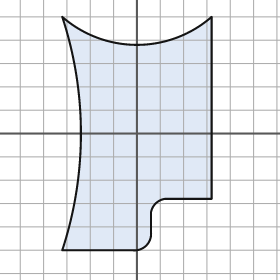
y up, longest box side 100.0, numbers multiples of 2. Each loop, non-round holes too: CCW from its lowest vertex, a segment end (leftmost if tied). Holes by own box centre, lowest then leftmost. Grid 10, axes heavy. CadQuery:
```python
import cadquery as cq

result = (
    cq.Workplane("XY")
    .moveTo(-32.0, -50.0)
    .lineTo(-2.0, -50.0)
    .threePointArc((4.0, -48.0), (6.0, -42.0))
    .lineTo(6.0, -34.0)
    .threePointArc((8.0, -30.0), (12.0, -28.0))
    .lineTo(32.0, -28.0)
    .lineTo(32.0, 50.0)
    .threePointArc((0.0, 38.0), (-32.0, 50.0))
    .threePointArc((-24.0, 0.0), (-32.0, -50.0))
    .close()
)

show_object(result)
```